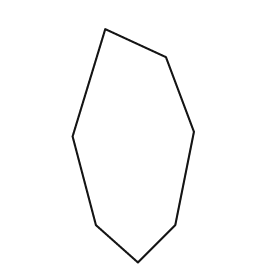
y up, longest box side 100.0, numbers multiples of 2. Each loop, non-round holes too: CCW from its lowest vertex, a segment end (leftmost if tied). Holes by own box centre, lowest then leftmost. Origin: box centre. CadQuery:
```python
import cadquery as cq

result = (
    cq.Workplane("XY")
    .moveTo(2.0, -50.0)
    .lineTo(18.0, -34.0)
    .lineTo(26.0, 6.0)
    .lineTo(14.0, 38.0)
    .lineTo(-12.0, 50.0)
    .lineTo(-26.0, 4.0)
    .lineTo(-16.0, -34.0)
    .close()
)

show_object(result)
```